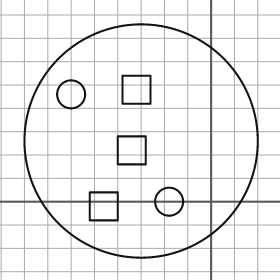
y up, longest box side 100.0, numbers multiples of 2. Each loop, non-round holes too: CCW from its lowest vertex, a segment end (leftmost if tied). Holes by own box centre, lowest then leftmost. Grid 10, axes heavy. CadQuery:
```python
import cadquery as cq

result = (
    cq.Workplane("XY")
    .moveTo(-30.0, 26.0)
    .circle(50.0)
    .moveTo(-52.0, -8.0)
    .lineTo(-40.0, -8.0)
    .lineTo(-40.0, 4.0)
    .lineTo(-52.0, 4.0)
    .close()
    .moveTo(-18.0, 0.0)
    .circle(6.0)
    .moveTo(-40.0, 16.0)
    .lineTo(-28.0, 16.0)
    .lineTo(-28.0, 28.0)
    .lineTo(-40.0, 28.0)
    .close()
    .moveTo(-60.0, 46.0)
    .circle(6.0)
    .moveTo(-38.0, 42.0)
    .lineTo(-26.0, 42.0)
    .lineTo(-26.0, 54.0)
    .lineTo(-38.0, 54.0)
    .close()
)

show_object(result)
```